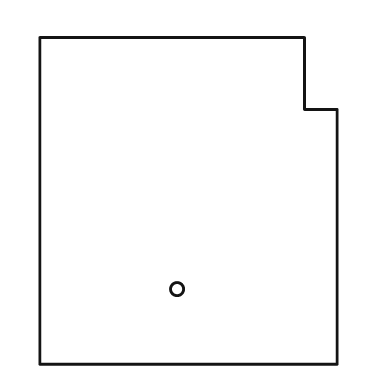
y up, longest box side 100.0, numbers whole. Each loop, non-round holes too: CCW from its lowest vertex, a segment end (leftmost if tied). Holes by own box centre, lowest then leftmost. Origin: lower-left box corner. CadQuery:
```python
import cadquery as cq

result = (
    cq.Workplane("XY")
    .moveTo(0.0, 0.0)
    .lineTo(91.0, 0.0)
    .lineTo(91.0, 78.0)
    .lineTo(81.0, 78.0)
    .lineTo(81.0, 100.0)
    .lineTo(0.0, 100.0)
    .close()
    .moveTo(42.0, 23.0)
    .circle(2.0)
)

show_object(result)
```